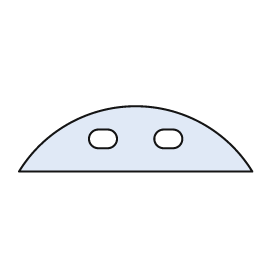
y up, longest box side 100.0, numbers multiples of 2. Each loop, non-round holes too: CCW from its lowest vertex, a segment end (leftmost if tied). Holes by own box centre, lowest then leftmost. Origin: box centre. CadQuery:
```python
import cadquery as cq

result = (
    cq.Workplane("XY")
    .moveTo(-50.0, -14.0)
    .lineTo(50.0, -14.0)
    .threePointArc((0.0, 14.0), (-50.0, -14.0))
    .close()
    .moveTo(-16.0, -4.0)
    .lineTo(-12.0, -4.0)
    .threePointArc((-8.0, 0.0), (-12.0, 4.0))
    .lineTo(-16.0, 4.0)
    .threePointArc((-20.0, 0.0), (-16.0, -4.0))
    .close()
    .moveTo(12.0, -4.0)
    .lineTo(16.0, -4.0)
    .threePointArc((20.0, 0.0), (16.0, 4.0))
    .lineTo(12.0, 4.0)
    .threePointArc((8.0, 0.0), (12.0, -4.0))
    .close()
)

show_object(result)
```